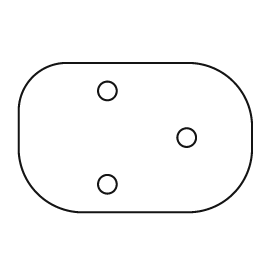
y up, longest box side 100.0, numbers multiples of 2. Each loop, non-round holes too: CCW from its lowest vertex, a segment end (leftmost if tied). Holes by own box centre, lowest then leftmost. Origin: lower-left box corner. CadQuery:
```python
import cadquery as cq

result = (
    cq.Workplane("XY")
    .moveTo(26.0, 0.0)
    .lineTo(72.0, 0.0)
    .threePointArc((92.0, 8.0), (100.0, 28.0))
    .lineTo(100.0, 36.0)
    .threePointArc((92.0, 56.0), (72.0, 64.0))
    .lineTo(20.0, 64.0)
    .threePointArc((6.0, 58.0), (0.0, 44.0))
    .lineTo(0.0, 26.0)
    .threePointArc((8.0, 8.0), (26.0, 0.0))
    .close()
    .moveTo(38.0, 12.0)
    .circle(4.0)
    .moveTo(72.0, 32.0)
    .circle(4.0)
    .moveTo(38.0, 52.0)
    .circle(4.0)
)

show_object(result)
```